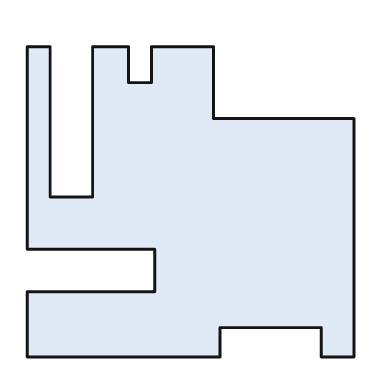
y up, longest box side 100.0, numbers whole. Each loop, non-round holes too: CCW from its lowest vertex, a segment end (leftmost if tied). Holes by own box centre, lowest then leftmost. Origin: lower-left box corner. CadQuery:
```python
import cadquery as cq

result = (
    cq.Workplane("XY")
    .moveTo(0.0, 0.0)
    .lineTo(59.0, 0.0)
    .lineTo(59.0, 9.0)
    .lineTo(90.0, 9.0)
    .lineTo(90.0, 0.0)
    .lineTo(100.0, 0.0)
    .lineTo(100.0, 73.0)
    .lineTo(57.0, 73.0)
    .lineTo(57.0, 95.0)
    .lineTo(38.0, 95.0)
    .lineTo(38.0, 84.0)
    .lineTo(31.0, 84.0)
    .lineTo(31.0, 95.0)
    .lineTo(20.0, 95.0)
    .lineTo(20.0, 49.0)
    .lineTo(7.0, 49.0)
    .lineTo(7.0, 95.0)
    .lineTo(0.0, 95.0)
    .lineTo(0.0, 33.0)
    .lineTo(39.0, 33.0)
    .lineTo(39.0, 20.0)
    .lineTo(0.0, 20.0)
    .close()
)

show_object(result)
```